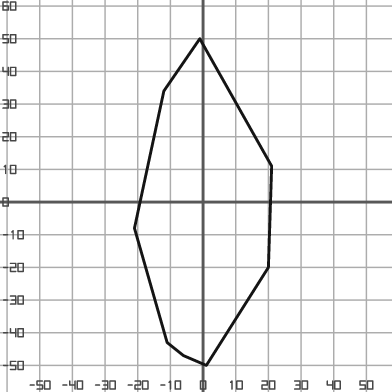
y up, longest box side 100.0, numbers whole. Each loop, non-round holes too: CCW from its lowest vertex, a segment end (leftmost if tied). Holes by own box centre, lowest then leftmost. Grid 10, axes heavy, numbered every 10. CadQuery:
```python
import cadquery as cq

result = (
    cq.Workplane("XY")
    .moveTo(1.0, -50.0)
    .lineTo(20.0, -20.0)
    .lineTo(21.0, 11.0)
    .lineTo(-1.0, 50.0)
    .lineTo(-12.0, 34.0)
    .lineTo(-21.0, -8.0)
    .lineTo(-11.0, -43.0)
    .lineTo(-6.0, -47.0)
    .close()
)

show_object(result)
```